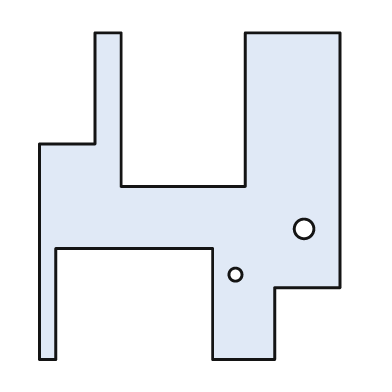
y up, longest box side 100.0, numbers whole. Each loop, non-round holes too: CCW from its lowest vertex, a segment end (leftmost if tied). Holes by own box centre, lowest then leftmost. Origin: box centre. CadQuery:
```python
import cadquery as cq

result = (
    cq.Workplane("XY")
    .moveTo(-46.0, -50.0)
    .lineTo(-41.0, -50.0)
    .lineTo(-41.0, -16.0)
    .lineTo(7.0, -16.0)
    .lineTo(7.0, -50.0)
    .lineTo(26.0, -50.0)
    .lineTo(26.0, -28.0)
    .lineTo(46.0, -28.0)
    .lineTo(46.0, 50.0)
    .lineTo(17.0, 50.0)
    .lineTo(17.0, 3.0)
    .lineTo(-21.0, 3.0)
    .lineTo(-21.0, 50.0)
    .lineTo(-29.0, 50.0)
    .lineTo(-29.0, 16.0)
    .lineTo(-46.0, 16.0)
    .close()
    .moveTo(14.0, -24.0)
    .circle(2.0)
    .moveTo(35.0, -10.0)
    .circle(3.0)
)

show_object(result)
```